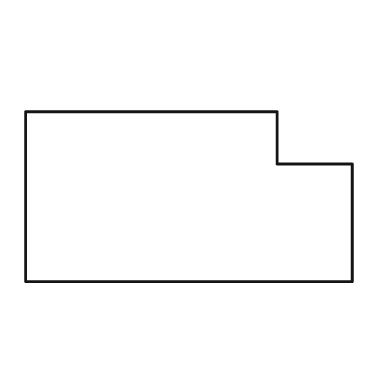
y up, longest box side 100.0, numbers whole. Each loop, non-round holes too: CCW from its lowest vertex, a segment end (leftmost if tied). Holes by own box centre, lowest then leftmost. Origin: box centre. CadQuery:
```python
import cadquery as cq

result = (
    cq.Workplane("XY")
    .moveTo(-50.0, -26.0)
    .lineTo(50.0, -26.0)
    .lineTo(50.0, 10.0)
    .lineTo(27.0, 10.0)
    .lineTo(27.0, 26.0)
    .lineTo(-50.0, 26.0)
    .close()
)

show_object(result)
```